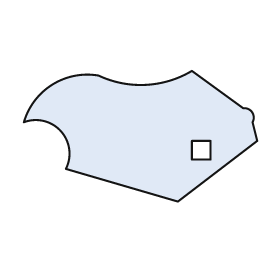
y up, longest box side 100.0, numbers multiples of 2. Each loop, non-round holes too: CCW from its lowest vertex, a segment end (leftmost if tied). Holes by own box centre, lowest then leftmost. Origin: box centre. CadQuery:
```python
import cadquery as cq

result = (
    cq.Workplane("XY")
    .moveTo(16.0, -28.0)
    .lineTo(50.0, -2.0)
    .lineTo(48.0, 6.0)
    .threePointArc((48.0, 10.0), (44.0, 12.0))
    .lineTo(22.0, 28.0)
    .threePointArc((2.0, 22.0), (-18.0, 26.0))
    .threePointArc((-38.0, 22.0), (-50.0, 6.0))
    .threePointArc((-34.0, 2.0), (-32.0, -14.0))
    .close()
    .moveTo(22.0, -10.0)
    .lineTo(30.0, -10.0)
    .lineTo(30.0, -2.0)
    .lineTo(22.0, -2.0)
    .close()
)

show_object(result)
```